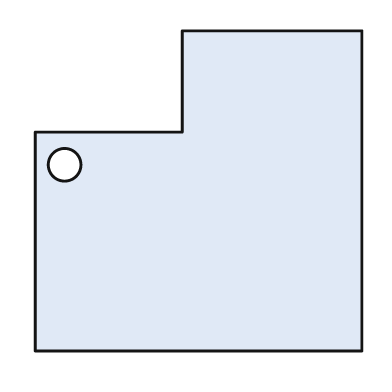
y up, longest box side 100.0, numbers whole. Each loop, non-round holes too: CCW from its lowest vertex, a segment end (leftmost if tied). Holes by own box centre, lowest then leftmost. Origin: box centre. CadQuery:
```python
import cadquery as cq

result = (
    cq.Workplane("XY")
    .moveTo(-50.0, -49.0)
    .lineTo(50.0, -49.0)
    .lineTo(50.0, 49.0)
    .lineTo(-5.0, 49.0)
    .lineTo(-5.0, 18.0)
    .lineTo(-50.0, 18.0)
    .close()
    .moveTo(-41.0, 8.0)
    .circle(5.0)
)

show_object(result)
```